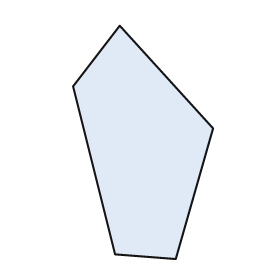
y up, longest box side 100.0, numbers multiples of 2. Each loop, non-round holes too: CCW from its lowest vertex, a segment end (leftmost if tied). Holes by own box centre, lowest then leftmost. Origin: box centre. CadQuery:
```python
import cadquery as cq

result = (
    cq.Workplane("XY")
    .moveTo(14.0, -50.0)
    .lineTo(30.0, 6.0)
    .lineTo(-10.0, 50.0)
    .lineTo(-30.0, 24.0)
    .lineTo(-12.0, -48.0)
    .close()
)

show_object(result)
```